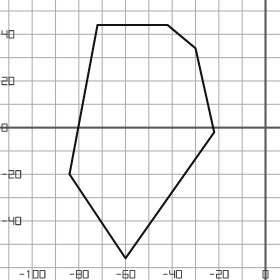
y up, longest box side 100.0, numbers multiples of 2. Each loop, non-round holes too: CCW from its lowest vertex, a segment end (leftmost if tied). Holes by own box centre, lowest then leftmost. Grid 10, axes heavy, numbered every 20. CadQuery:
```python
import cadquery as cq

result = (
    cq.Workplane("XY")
    .moveTo(-60.0, -56.0)
    .lineTo(-22.0, -2.0)
    .lineTo(-30.0, 34.0)
    .lineTo(-42.0, 44.0)
    .lineTo(-72.0, 44.0)
    .lineTo(-84.0, -20.0)
    .close()
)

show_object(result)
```